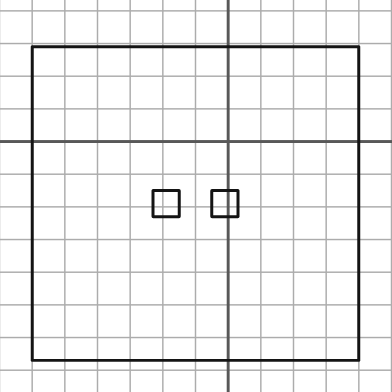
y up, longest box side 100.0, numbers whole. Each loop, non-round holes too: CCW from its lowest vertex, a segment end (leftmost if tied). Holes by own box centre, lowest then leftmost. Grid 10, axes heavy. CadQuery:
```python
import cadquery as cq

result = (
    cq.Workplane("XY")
    .moveTo(-60.0, -67.0)
    .lineTo(40.0, -67.0)
    .lineTo(40.0, 29.0)
    .lineTo(-60.0, 29.0)
    .close()
    .moveTo(-23.0, -23.0)
    .lineTo(-15.0, -23.0)
    .lineTo(-15.0, -15.0)
    .lineTo(-23.0, -15.0)
    .close()
    .moveTo(-5.0, -23.0)
    .lineTo(3.0, -23.0)
    .lineTo(3.0, -15.0)
    .lineTo(-5.0, -15.0)
    .close()
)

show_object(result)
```